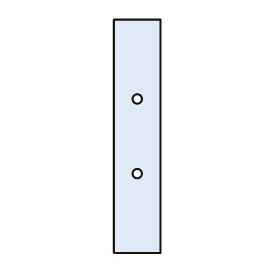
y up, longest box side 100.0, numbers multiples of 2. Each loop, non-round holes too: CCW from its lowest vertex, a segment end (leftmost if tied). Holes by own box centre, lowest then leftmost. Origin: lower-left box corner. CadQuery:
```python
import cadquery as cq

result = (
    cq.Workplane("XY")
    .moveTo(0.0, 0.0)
    .lineTo(20.0, 0.0)
    .lineTo(20.0, 100.0)
    .lineTo(0.0, 100.0)
    .close()
    .moveTo(10.0, 34.0)
    .circle(2.0)
    .moveTo(10.0, 66.0)
    .circle(2.0)
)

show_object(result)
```